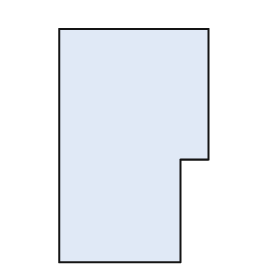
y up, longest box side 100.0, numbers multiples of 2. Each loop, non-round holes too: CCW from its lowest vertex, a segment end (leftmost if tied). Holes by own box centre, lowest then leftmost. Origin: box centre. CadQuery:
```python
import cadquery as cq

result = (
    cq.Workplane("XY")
    .moveTo(-32.0, -50.0)
    .lineTo(20.0, -50.0)
    .lineTo(20.0, -6.0)
    .lineTo(32.0, -6.0)
    .lineTo(32.0, 50.0)
    .lineTo(-32.0, 50.0)
    .close()
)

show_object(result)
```